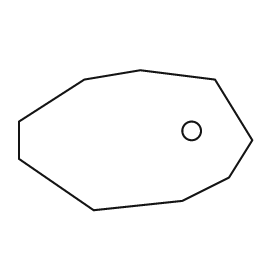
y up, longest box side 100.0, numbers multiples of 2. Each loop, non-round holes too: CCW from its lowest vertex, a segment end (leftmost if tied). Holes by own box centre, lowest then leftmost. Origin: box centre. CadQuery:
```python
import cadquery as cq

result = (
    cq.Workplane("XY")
    .moveTo(-18.0, -30.0)
    .lineTo(20.0, -26.0)
    .lineTo(40.0, -16.0)
    .lineTo(50.0, 0.0)
    .lineTo(34.0, 26.0)
    .lineTo(2.0, 30.0)
    .lineTo(-22.0, 26.0)
    .lineTo(-50.0, 8.0)
    .lineTo(-50.0, -8.0)
    .close()
    .moveTo(24.0, 4.0)
    .circle(4.0)
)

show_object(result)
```